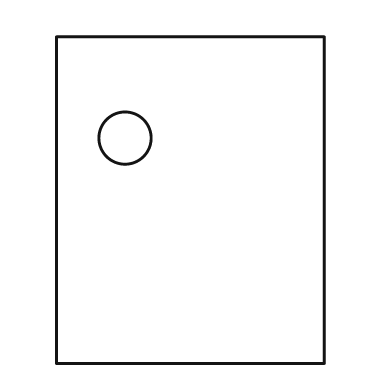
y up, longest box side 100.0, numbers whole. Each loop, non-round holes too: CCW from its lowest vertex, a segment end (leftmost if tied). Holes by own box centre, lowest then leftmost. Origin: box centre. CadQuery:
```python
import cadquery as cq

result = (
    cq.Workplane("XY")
    .moveTo(-41.0, -50.0)
    .lineTo(41.0, -50.0)
    .lineTo(41.0, 50.0)
    .lineTo(-41.0, 50.0)
    .close()
    .moveTo(-20.0, 19.0)
    .circle(8.0)
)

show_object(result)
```